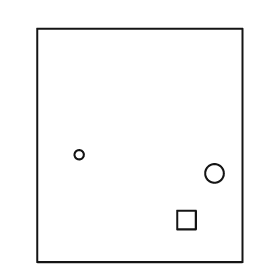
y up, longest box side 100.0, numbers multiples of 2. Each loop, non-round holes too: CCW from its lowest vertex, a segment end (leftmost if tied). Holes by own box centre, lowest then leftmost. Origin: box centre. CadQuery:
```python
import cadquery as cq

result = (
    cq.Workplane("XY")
    .moveTo(-44.0, -50.0)
    .lineTo(44.0, -50.0)
    .lineTo(44.0, 50.0)
    .lineTo(-44.0, 50.0)
    .close()
    .moveTo(16.0, -36.0)
    .lineTo(24.0, -36.0)
    .lineTo(24.0, -28.0)
    .lineTo(16.0, -28.0)
    .close()
    .moveTo(32.0, -12.0)
    .circle(4.0)
    .moveTo(-26.0, -4.0)
    .circle(2.0)
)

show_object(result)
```